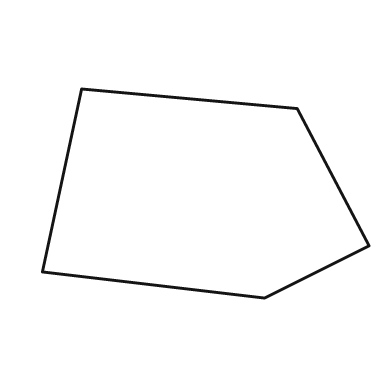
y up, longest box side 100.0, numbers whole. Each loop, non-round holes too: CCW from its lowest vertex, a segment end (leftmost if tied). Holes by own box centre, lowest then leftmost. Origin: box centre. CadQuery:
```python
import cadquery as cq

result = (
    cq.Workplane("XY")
    .moveTo(18.0, -32.0)
    .lineTo(50.0, -16.0)
    .lineTo(28.0, 26.0)
    .lineTo(-38.0, 32.0)
    .lineTo(-50.0, -24.0)
    .close()
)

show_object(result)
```